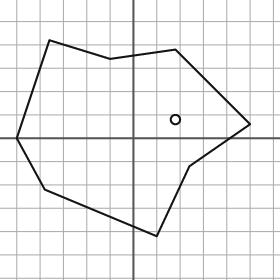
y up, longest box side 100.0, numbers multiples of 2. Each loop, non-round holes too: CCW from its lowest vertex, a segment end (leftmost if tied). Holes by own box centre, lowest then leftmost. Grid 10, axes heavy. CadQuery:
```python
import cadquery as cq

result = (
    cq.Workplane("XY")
    .moveTo(10.0, -42.0)
    .lineTo(24.0, -12.0)
    .lineTo(50.0, 6.0)
    .lineTo(18.0, 38.0)
    .lineTo(-10.0, 34.0)
    .lineTo(-36.0, 42.0)
    .lineTo(-50.0, 0.0)
    .lineTo(-38.0, -22.0)
    .close()
    .moveTo(18.0, 8.0)
    .circle(2.0)
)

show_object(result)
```